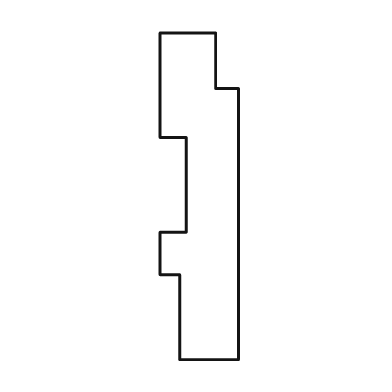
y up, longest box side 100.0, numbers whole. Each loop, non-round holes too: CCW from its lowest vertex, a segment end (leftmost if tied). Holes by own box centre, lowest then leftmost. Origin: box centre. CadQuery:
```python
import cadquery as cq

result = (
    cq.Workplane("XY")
    .moveTo(-6.0, -50.0)
    .lineTo(12.0, -50.0)
    .lineTo(12.0, 33.0)
    .lineTo(5.0, 33.0)
    .lineTo(5.0, 50.0)
    .lineTo(-12.0, 50.0)
    .lineTo(-12.0, 18.0)
    .lineTo(-4.0, 18.0)
    .lineTo(-4.0, -11.0)
    .lineTo(-12.0, -11.0)
    .lineTo(-12.0, -24.0)
    .lineTo(-6.0, -24.0)
    .close()
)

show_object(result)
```